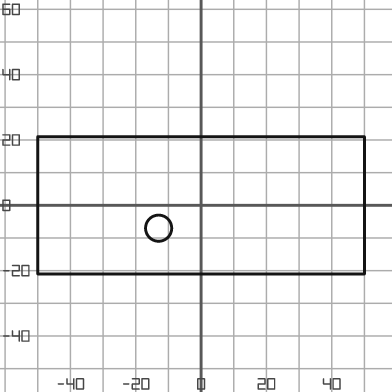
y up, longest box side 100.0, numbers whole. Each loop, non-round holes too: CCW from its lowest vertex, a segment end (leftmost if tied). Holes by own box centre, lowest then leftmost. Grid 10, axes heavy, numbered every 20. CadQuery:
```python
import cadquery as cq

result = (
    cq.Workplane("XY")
    .moveTo(-50.0, -21.0)
    .lineTo(50.0, -21.0)
    .lineTo(50.0, 21.0)
    .lineTo(-50.0, 21.0)
    .close()
    .moveTo(-13.0, -7.0)
    .circle(4.0)
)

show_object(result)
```